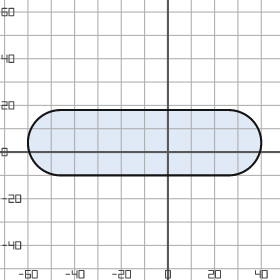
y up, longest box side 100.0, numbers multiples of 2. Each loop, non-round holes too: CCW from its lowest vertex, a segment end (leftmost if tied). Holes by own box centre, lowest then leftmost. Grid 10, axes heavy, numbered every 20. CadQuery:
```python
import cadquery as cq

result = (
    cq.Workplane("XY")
    .moveTo(-46.0, -10.0)
    .lineTo(26.0, -10.0)
    .threePointArc((40.0, 4.0), (26.0, 18.0))
    .lineTo(-46.0, 18.0)
    .threePointArc((-60.0, 4.0), (-46.0, -10.0))
    .close()
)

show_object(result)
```